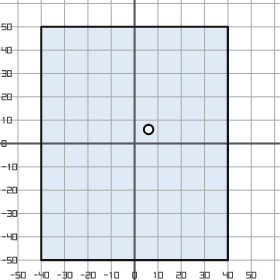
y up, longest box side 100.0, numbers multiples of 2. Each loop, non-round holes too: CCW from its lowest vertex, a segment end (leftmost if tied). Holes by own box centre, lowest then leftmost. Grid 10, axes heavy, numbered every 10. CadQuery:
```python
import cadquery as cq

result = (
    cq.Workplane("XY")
    .moveTo(-40.0, -50.0)
    .lineTo(40.0, -50.0)
    .lineTo(40.0, 50.0)
    .lineTo(-40.0, 50.0)
    .close()
    .moveTo(6.0, 6.0)
    .circle(2.0)
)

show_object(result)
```